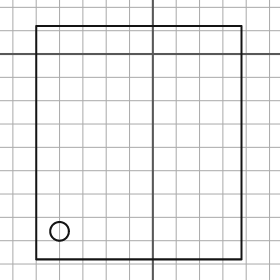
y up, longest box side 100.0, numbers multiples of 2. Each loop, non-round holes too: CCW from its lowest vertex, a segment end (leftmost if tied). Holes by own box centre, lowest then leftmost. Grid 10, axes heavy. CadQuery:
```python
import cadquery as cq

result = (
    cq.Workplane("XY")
    .moveTo(-50.0, -88.0)
    .lineTo(38.0, -88.0)
    .lineTo(38.0, 12.0)
    .lineTo(-50.0, 12.0)
    .close()
    .moveTo(-40.0, -76.0)
    .circle(4.0)
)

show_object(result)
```